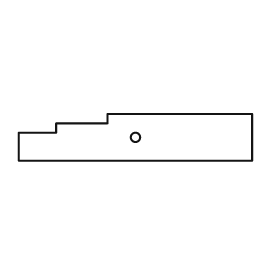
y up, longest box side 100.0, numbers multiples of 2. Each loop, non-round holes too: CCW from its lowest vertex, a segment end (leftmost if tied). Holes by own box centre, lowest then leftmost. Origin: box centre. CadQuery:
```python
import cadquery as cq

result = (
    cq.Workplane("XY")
    .moveTo(-50.0, -10.0)
    .lineTo(50.0, -10.0)
    .lineTo(50.0, 10.0)
    .lineTo(-12.0, 10.0)
    .lineTo(-12.0, 6.0)
    .lineTo(-34.0, 6.0)
    .lineTo(-34.0, 2.0)
    .lineTo(-50.0, 2.0)
    .close()
    .moveTo(0.0, 0.0)
    .circle(2.0)
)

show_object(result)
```